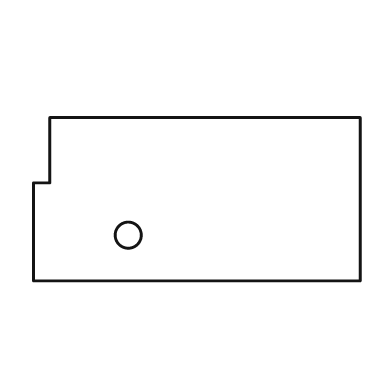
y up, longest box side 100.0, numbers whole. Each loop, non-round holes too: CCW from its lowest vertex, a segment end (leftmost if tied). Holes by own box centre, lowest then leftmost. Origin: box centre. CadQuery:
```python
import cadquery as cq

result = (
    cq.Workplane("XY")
    .moveTo(-50.0, -25.0)
    .lineTo(50.0, -25.0)
    .lineTo(50.0, 25.0)
    .lineTo(-45.0, 25.0)
    .lineTo(-45.0, 5.0)
    .lineTo(-50.0, 5.0)
    .close()
    .moveTo(-21.0, -11.0)
    .circle(4.0)
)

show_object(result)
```